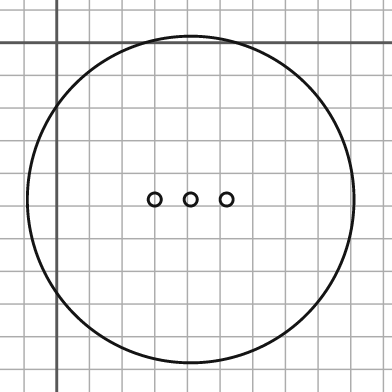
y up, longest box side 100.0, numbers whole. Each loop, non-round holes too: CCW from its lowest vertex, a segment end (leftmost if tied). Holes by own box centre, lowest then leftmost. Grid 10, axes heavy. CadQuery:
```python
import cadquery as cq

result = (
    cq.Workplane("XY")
    .moveTo(41.0, -48.0)
    .circle(50.0)
    .moveTo(30.0, -48.0)
    .circle(2.0)
    .moveTo(41.0, -48.0)
    .circle(2.0)
    .moveTo(52.0, -48.0)
    .circle(2.0)
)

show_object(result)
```